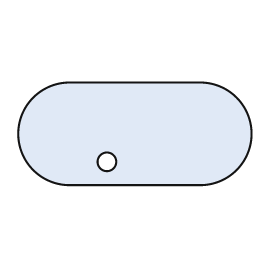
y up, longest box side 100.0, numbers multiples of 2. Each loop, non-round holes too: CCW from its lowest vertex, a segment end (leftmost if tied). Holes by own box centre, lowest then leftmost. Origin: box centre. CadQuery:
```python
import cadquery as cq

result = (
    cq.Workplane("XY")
    .moveTo(-28.0, -22.0)
    .lineTo(28.0, -22.0)
    .threePointArc((50.0, 0.0), (28.0, 22.0))
    .lineTo(-28.0, 22.0)
    .threePointArc((-50.0, 0.0), (-28.0, -22.0))
    .close()
    .moveTo(-12.0, -12.0)
    .circle(4.0)
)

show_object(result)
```